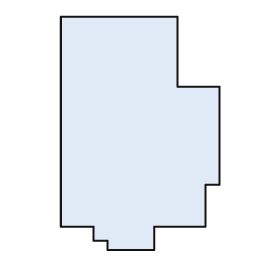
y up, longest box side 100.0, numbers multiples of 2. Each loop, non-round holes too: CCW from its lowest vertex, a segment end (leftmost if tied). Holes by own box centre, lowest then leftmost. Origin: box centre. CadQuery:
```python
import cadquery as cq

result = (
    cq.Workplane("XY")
    .moveTo(-14.0, -50.0)
    .lineTo(6.0, -50.0)
    .lineTo(6.0, -40.0)
    .lineTo(28.0, -40.0)
    .lineTo(28.0, -22.0)
    .lineTo(34.0, -22.0)
    .lineTo(34.0, 20.0)
    .lineTo(16.0, 20.0)
    .lineTo(16.0, 50.0)
    .lineTo(-34.0, 50.0)
    .lineTo(-34.0, -40.0)
    .lineTo(-20.0, -40.0)
    .lineTo(-20.0, -46.0)
    .lineTo(-14.0, -46.0)
    .close()
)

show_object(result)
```